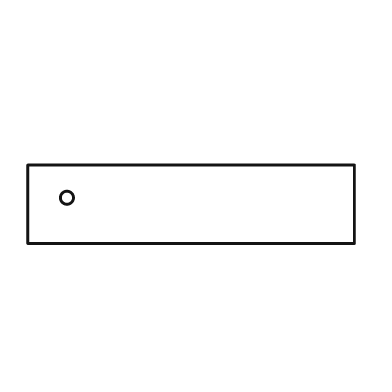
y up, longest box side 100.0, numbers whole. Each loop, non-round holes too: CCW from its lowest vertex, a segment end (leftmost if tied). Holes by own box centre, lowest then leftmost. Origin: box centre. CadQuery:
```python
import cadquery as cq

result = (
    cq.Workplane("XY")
    .moveTo(-50.0, -12.0)
    .lineTo(50.0, -12.0)
    .lineTo(50.0, 12.0)
    .lineTo(-50.0, 12.0)
    .close()
    .moveTo(-38.0, 2.0)
    .circle(2.0)
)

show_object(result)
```